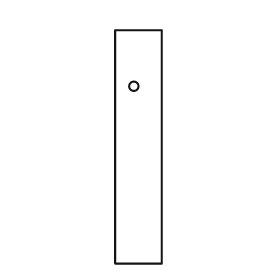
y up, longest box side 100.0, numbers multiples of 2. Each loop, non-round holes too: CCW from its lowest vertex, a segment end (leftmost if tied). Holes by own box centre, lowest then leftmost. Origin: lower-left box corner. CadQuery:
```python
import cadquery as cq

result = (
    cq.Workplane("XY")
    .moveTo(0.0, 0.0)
    .lineTo(20.0, 0.0)
    .lineTo(20.0, 100.0)
    .lineTo(0.0, 100.0)
    .close()
    .moveTo(8.0, 76.0)
    .circle(2.0)
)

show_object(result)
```